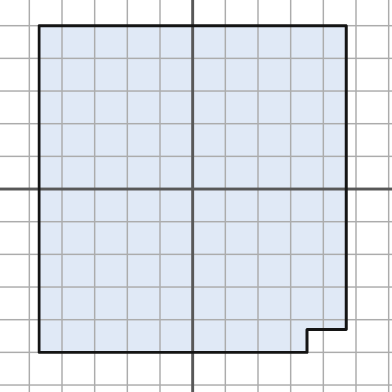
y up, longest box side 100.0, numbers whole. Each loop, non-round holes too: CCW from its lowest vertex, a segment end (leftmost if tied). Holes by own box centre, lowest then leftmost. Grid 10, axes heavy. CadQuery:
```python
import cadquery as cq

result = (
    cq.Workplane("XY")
    .moveTo(-47.0, -50.0)
    .lineTo(35.0, -50.0)
    .lineTo(35.0, -43.0)
    .lineTo(47.0, -43.0)
    .lineTo(47.0, 50.0)
    .lineTo(-47.0, 50.0)
    .close()
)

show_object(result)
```